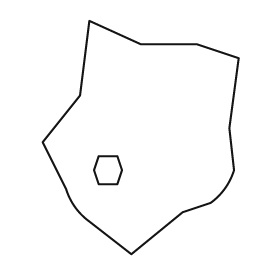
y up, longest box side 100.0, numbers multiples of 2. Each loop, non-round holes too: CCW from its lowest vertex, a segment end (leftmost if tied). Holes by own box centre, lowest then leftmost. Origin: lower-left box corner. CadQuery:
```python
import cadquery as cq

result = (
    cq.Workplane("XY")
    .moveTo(38.0, 0.0)
    .lineTo(60.0, 18.0)
    .lineTo(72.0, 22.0)
    .threePointArc((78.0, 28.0), (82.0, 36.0))
    .lineTo(80.0, 54.0)
    .lineTo(84.0, 84.0)
    .lineTo(66.0, 90.0)
    .lineTo(42.0, 90.0)
    .lineTo(20.0, 100.0)
    .lineTo(16.0, 68.0)
    .lineTo(0.0, 48.0)
    .lineTo(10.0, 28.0)
    .threePointArc((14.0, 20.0), (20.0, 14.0))
    .close()
    .moveTo(24.0, 30.0)
    .lineTo(32.0, 30.0)
    .lineTo(34.0, 36.0)
    .lineTo(32.0, 42.0)
    .lineTo(24.0, 42.0)
    .lineTo(22.0, 36.0)
    .close()
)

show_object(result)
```